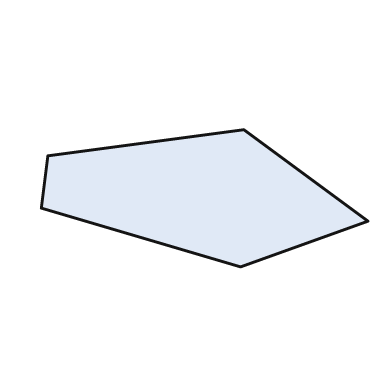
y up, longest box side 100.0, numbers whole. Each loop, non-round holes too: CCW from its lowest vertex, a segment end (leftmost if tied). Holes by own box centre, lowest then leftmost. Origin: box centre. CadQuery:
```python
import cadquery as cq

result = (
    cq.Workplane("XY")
    .moveTo(11.0, -21.0)
    .lineTo(50.0, -7.0)
    .lineTo(12.0, 21.0)
    .lineTo(-48.0, 13.0)
    .lineTo(-50.0, -3.0)
    .close()
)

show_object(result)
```